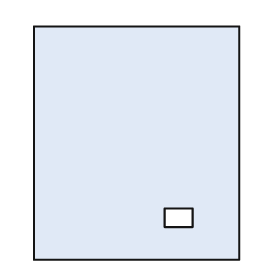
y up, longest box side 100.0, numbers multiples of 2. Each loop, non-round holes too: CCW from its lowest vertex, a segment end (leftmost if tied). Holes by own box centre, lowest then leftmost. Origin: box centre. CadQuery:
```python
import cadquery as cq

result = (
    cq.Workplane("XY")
    .moveTo(-44.0, -50.0)
    .lineTo(44.0, -50.0)
    .lineTo(44.0, 50.0)
    .lineTo(-44.0, 50.0)
    .close()
    .moveTo(12.0, -36.0)
    .lineTo(24.0, -36.0)
    .lineTo(24.0, -28.0)
    .lineTo(12.0, -28.0)
    .close()
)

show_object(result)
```